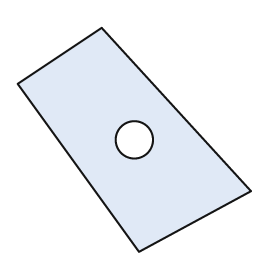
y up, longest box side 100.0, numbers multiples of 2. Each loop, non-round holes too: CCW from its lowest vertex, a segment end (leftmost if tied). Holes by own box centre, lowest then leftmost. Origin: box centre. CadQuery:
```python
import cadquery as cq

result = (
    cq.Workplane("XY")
    .moveTo(2.0, -48.0)
    .lineTo(50.0, -22.0)
    .lineTo(-14.0, 48.0)
    .lineTo(-50.0, 24.0)
    .close()
    .moveTo(0.0, 0.0)
    .circle(8.0)
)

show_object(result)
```